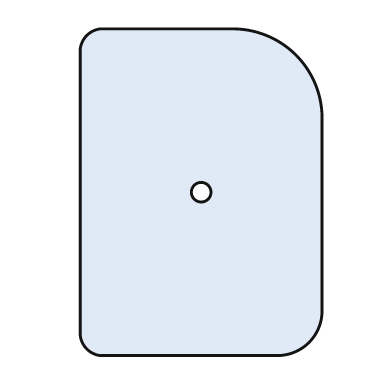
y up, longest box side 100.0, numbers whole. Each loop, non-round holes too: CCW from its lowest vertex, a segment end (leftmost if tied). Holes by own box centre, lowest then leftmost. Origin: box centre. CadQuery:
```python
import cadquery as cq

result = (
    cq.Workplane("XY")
    .moveTo(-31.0, -50.0)
    .lineTo(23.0, -50.0)
    .threePointArc((33.0, -46.0), (37.0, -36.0))
    .lineTo(37.0, 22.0)
    .threePointArc((29.0, 42.0), (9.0, 50.0))
    .lineTo(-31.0, 50.0)
    .threePointArc((-35.0, 48.0), (-37.0, 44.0))
    .lineTo(-37.0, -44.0)
    .threePointArc((-35.0, -48.0), (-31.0, -50.0))
    .close()
    .moveTo(0.0, 0.0)
    .circle(3.0)
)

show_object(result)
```